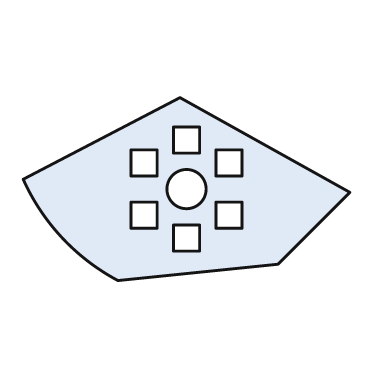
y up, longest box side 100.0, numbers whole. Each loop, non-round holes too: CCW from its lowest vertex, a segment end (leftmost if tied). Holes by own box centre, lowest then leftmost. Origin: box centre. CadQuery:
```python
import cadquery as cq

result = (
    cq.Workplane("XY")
    .moveTo(-21.0, -28.0)
    .lineTo(28.0, -23.0)
    .lineTo(50.0, -1.0)
    .lineTo(-2.0, 28.0)
    .lineTo(-50.0, 3.0)
    .threePointArc((-38.0, -15.0), (-21.0, -28.0))
    .close()
    .moveTo(-4.0, -19.0)
    .lineTo(4.0, -19.0)
    .lineTo(4.0, -11.0)
    .lineTo(-4.0, -11.0)
    .close()
    .moveTo(-17.0, -12.0)
    .lineTo(-9.0, -12.0)
    .lineTo(-9.0, -4.0)
    .lineTo(-17.0, -4.0)
    .close()
    .moveTo(9.0, -12.0)
    .lineTo(17.0, -12.0)
    .lineTo(17.0, -4.0)
    .lineTo(9.0, -4.0)
    .close()
    .moveTo(0.0, 0.0)
    .circle(6.0)
    .moveTo(-17.0, 4.0)
    .lineTo(-9.0, 4.0)
    .lineTo(-9.0, 12.0)
    .lineTo(-17.0, 12.0)
    .close()
    .moveTo(9.0, 4.0)
    .lineTo(17.0, 4.0)
    .lineTo(17.0, 12.0)
    .lineTo(9.0, 12.0)
    .close()
    .moveTo(-4.0, 11.0)
    .lineTo(4.0, 11.0)
    .lineTo(4.0, 19.0)
    .lineTo(-4.0, 19.0)
    .close()
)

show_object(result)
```